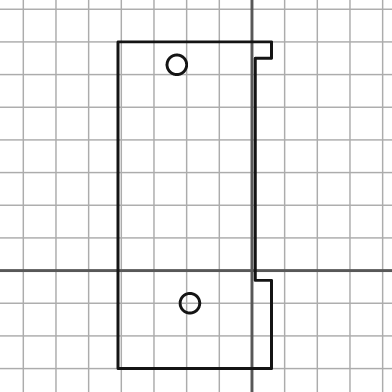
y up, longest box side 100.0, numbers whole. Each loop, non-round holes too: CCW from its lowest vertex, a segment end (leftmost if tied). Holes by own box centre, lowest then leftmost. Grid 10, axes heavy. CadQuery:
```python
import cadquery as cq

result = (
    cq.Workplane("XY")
    .moveTo(-41.0, -30.0)
    .lineTo(6.0, -30.0)
    .lineTo(6.0, -3.0)
    .lineTo(1.0, -3.0)
    .lineTo(1.0, 65.0)
    .lineTo(6.0, 65.0)
    .lineTo(6.0, 70.0)
    .lineTo(-41.0, 70.0)
    .close()
    .moveTo(-19.0, -10.0)
    .circle(3.0)
    .moveTo(-23.0, 63.0)
    .circle(3.0)
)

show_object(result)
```